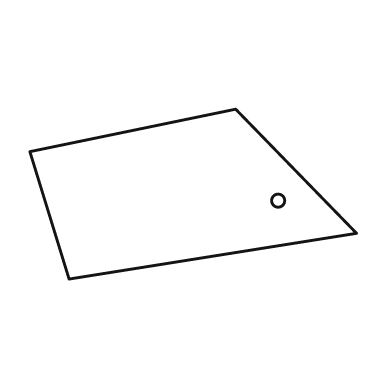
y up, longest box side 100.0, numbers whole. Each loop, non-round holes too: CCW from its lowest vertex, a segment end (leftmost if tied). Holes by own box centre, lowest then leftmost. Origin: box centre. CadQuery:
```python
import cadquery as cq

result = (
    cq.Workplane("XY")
    .moveTo(-38.0, -26.0)
    .lineTo(50.0, -12.0)
    .lineTo(13.0, 26.0)
    .lineTo(-50.0, 13.0)
    .close()
    .moveTo(26.0, -2.0)
    .circle(2.0)
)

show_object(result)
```